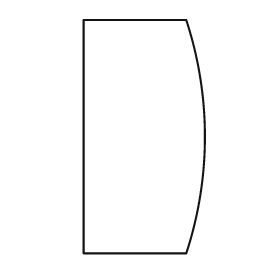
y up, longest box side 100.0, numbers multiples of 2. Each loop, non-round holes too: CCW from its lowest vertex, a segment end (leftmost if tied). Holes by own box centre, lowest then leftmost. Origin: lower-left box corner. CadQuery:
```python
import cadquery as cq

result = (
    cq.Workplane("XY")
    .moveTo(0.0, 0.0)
    .lineTo(44.0, 0.0)
    .threePointArc((52.0, 50.0), (44.0, 100.0))
    .lineTo(0.0, 100.0)
    .close()
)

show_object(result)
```